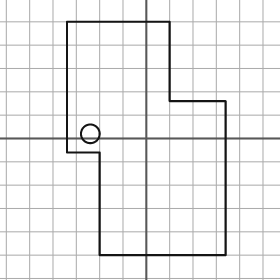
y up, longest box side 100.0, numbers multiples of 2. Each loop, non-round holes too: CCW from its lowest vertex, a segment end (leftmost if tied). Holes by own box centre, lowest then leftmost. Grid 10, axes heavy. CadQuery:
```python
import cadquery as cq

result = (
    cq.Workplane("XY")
    .moveTo(-20.0, -50.0)
    .lineTo(34.0, -50.0)
    .lineTo(34.0, 16.0)
    .lineTo(10.0, 16.0)
    .lineTo(10.0, 50.0)
    .lineTo(-34.0, 50.0)
    .lineTo(-34.0, -6.0)
    .lineTo(-20.0, -6.0)
    .close()
    .moveTo(-24.0, 2.0)
    .circle(4.0)
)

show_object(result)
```